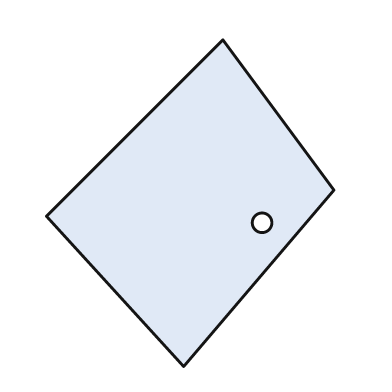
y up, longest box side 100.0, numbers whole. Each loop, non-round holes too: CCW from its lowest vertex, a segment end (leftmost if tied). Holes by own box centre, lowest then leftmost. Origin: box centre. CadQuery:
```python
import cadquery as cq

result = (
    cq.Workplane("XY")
    .moveTo(-2.0, -50.0)
    .lineTo(44.0, 4.0)
    .lineTo(10.0, 50.0)
    .lineTo(-44.0, -4.0)
    .close()
    .moveTo(22.0, -6.0)
    .circle(3.0)
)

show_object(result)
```